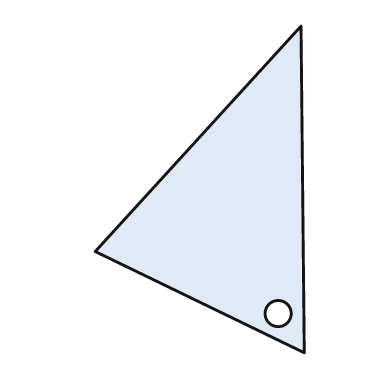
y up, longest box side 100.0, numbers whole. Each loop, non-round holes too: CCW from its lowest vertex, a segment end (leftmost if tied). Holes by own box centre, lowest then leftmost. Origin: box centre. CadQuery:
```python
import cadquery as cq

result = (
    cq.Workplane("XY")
    .moveTo(32.0, -50.0)
    .lineTo(31.0, 50.0)
    .lineTo(-32.0, -19.0)
    .close()
    .moveTo(24.0, -38.0)
    .circle(4.0)
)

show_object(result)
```